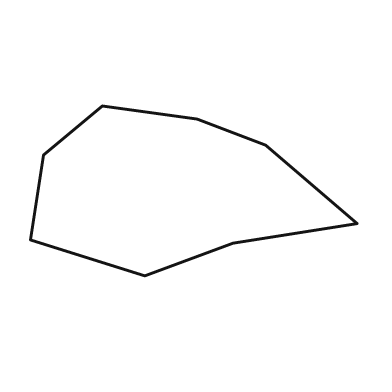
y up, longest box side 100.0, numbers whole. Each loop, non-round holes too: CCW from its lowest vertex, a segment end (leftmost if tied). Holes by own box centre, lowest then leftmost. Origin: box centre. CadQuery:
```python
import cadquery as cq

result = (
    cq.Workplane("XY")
    .moveTo(-15.0, -26.0)
    .lineTo(12.0, -16.0)
    .lineTo(50.0, -10.0)
    .lineTo(22.0, 14.0)
    .lineTo(1.0, 22.0)
    .lineTo(-28.0, 26.0)
    .lineTo(-46.0, 11.0)
    .lineTo(-50.0, -15.0)
    .close()
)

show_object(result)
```